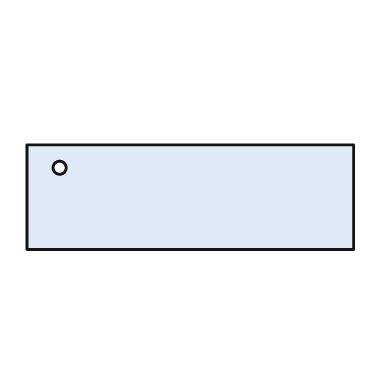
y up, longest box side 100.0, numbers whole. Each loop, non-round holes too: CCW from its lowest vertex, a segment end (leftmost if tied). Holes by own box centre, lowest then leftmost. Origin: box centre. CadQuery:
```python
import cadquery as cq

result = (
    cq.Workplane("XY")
    .moveTo(-50.0, -16.0)
    .lineTo(50.0, -16.0)
    .lineTo(50.0, 16.0)
    .lineTo(-50.0, 16.0)
    .close()
    .moveTo(-40.0, 9.0)
    .circle(2.0)
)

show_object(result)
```